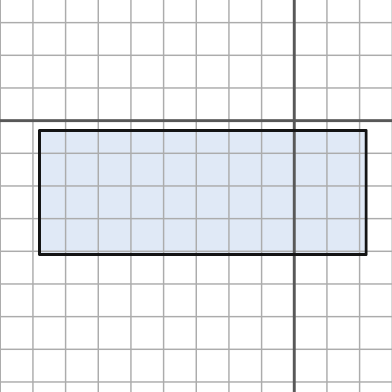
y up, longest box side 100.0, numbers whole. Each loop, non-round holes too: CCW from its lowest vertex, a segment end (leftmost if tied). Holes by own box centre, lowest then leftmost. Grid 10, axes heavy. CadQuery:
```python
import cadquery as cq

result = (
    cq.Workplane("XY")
    .moveTo(-78.0, -41.0)
    .lineTo(22.0, -41.0)
    .lineTo(22.0, -3.0)
    .lineTo(-78.0, -3.0)
    .close()
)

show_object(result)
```